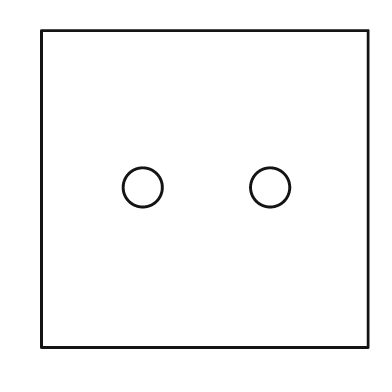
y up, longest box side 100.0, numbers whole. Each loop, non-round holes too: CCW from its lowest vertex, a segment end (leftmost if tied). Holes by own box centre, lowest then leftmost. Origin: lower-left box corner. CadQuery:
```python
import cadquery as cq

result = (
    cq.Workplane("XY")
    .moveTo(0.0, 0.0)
    .lineTo(100.0, 0.0)
    .lineTo(100.0, 97.0)
    .lineTo(0.0, 97.0)
    .close()
    .moveTo(31.0, 49.0)
    .circle(6.0)
    .moveTo(70.0, 49.0)
    .circle(6.0)
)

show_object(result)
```